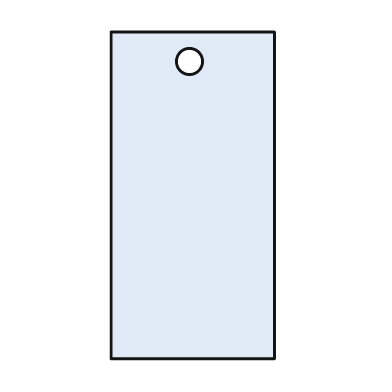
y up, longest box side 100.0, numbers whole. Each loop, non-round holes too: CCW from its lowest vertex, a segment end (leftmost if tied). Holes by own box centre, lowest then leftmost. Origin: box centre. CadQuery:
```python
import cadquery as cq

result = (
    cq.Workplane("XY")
    .moveTo(-25.0, -50.0)
    .lineTo(25.0, -50.0)
    .lineTo(25.0, 50.0)
    .lineTo(-25.0, 50.0)
    .close()
    .moveTo(-1.0, 41.0)
    .circle(4.0)
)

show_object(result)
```